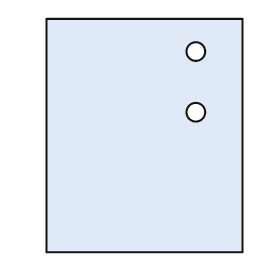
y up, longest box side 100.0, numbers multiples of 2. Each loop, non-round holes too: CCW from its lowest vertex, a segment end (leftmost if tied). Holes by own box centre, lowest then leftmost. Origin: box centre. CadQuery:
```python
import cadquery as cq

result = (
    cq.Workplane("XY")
    .moveTo(-42.0, -50.0)
    .lineTo(42.0, -50.0)
    .lineTo(42.0, 50.0)
    .lineTo(-42.0, 50.0)
    .close()
    .moveTo(22.0, 10.0)
    .circle(4.0)
    .moveTo(22.0, 36.0)
    .circle(4.0)
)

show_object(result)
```